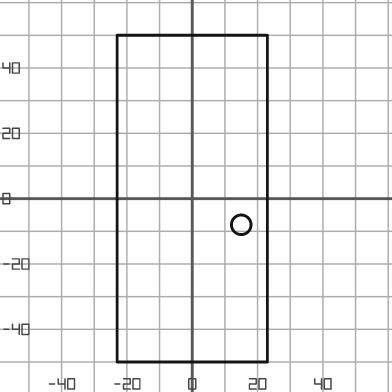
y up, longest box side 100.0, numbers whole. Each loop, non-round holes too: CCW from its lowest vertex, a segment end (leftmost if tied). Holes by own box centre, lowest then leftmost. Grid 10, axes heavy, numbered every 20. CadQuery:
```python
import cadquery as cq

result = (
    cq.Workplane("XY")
    .moveTo(-23.0, -50.0)
    .lineTo(23.0, -50.0)
    .lineTo(23.0, 50.0)
    .lineTo(-23.0, 50.0)
    .close()
    .moveTo(15.0, -8.0)
    .circle(3.0)
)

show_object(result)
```